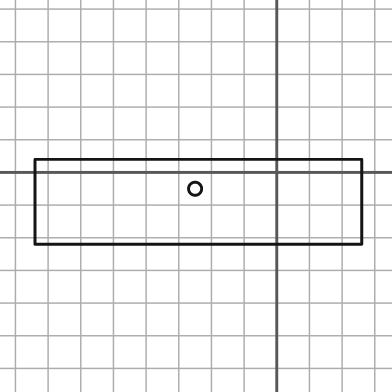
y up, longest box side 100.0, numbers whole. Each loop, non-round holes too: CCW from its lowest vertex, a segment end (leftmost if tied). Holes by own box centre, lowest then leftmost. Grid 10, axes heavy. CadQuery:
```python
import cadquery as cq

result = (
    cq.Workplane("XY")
    .moveTo(-74.0, -22.0)
    .lineTo(26.0, -22.0)
    .lineTo(26.0, 4.0)
    .lineTo(-74.0, 4.0)
    .close()
    .moveTo(-25.0, -5.0)
    .circle(2.0)
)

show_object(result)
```